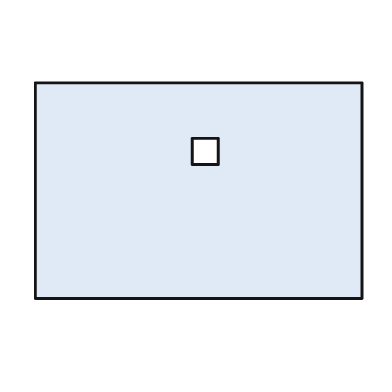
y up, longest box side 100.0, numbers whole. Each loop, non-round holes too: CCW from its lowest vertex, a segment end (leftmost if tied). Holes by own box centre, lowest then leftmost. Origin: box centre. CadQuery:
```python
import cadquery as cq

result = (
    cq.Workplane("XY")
    .moveTo(-50.0, -33.0)
    .lineTo(50.0, -33.0)
    .lineTo(50.0, 33.0)
    .lineTo(-50.0, 33.0)
    .close()
    .moveTo(-2.0, 8.0)
    .lineTo(6.0, 8.0)
    .lineTo(6.0, 16.0)
    .lineTo(-2.0, 16.0)
    .close()
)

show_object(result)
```